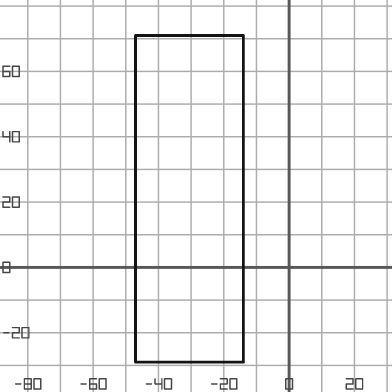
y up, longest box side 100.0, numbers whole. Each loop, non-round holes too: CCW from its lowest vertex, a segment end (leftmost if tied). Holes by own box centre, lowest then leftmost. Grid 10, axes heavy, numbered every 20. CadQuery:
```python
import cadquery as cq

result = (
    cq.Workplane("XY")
    .moveTo(-47.0, -29.0)
    .lineTo(-14.0, -29.0)
    .lineTo(-14.0, 71.0)
    .lineTo(-47.0, 71.0)
    .close()
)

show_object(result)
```